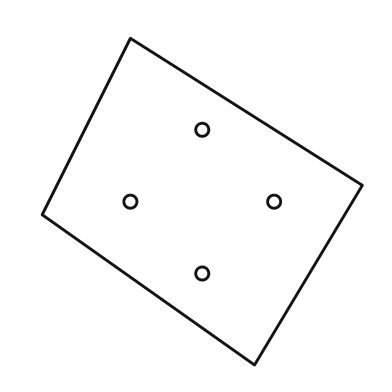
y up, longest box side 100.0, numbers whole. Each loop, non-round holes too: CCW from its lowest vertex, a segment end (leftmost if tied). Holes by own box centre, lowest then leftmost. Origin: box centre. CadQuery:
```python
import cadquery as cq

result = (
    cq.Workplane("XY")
    .moveTo(16.0, -50.0)
    .lineTo(49.0, 5.0)
    .lineTo(-22.0, 50.0)
    .lineTo(-49.0, -4.0)
    .close()
    .moveTo(0.0, -22.0)
    .circle(2.0)
    .moveTo(-22.0, 0.0)
    .circle(2.0)
    .moveTo(22.0, 0.0)
    .circle(2.0)
    .moveTo(0.0, 22.0)
    .circle(2.0)
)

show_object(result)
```